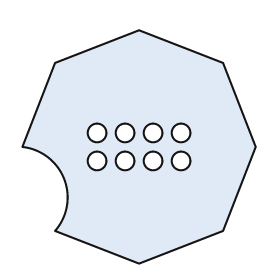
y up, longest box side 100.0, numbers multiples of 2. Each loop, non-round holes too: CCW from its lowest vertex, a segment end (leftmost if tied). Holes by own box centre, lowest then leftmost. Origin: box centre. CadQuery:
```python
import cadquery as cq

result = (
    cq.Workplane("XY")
    .moveTo(0.0, -50.0)
    .lineTo(36.0, -36.0)
    .lineTo(50.0, 0.0)
    .lineTo(36.0, 36.0)
    .lineTo(0.0, 50.0)
    .lineTo(-36.0, 36.0)
    .lineTo(-50.0, 0.0)
    .threePointArc((-32.0, -14.0), (-36.0, -36.0))
    .close()
    .moveTo(-18.0, -6.0)
    .circle(4.0)
    .moveTo(-6.0, -6.0)
    .circle(4.0)
    .moveTo(6.0, -6.0)
    .circle(4.0)
    .moveTo(18.0, -6.0)
    .circle(4.0)
    .moveTo(-18.0, 6.0)
    .circle(4.0)
    .moveTo(-6.0, 6.0)
    .circle(4.0)
    .moveTo(6.0, 6.0)
    .circle(4.0)
    .moveTo(18.0, 6.0)
    .circle(4.0)
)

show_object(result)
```